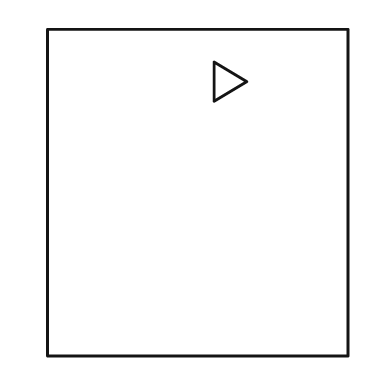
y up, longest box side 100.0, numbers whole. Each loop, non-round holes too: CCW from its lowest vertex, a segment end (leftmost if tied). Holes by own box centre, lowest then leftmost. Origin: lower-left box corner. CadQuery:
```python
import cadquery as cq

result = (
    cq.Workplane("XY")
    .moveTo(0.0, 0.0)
    .lineTo(92.0, 0.0)
    .lineTo(92.0, 100.0)
    .lineTo(0.0, 100.0)
    .close()
    .moveTo(51.0, 78.0)
    .lineTo(61.0, 84.0)
    .lineTo(51.0, 90.0)
    .close()
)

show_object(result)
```